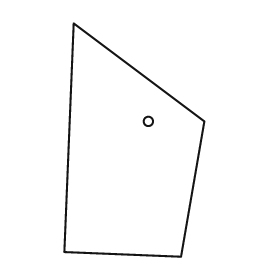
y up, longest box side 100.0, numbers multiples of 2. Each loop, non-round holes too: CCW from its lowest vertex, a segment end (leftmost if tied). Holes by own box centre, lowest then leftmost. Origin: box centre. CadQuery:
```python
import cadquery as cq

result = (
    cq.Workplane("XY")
    .moveTo(20.0, -50.0)
    .lineTo(30.0, 8.0)
    .lineTo(-26.0, 50.0)
    .lineTo(-30.0, -48.0)
    .close()
    .moveTo(6.0, 8.0)
    .circle(2.0)
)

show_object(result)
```